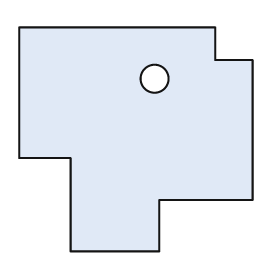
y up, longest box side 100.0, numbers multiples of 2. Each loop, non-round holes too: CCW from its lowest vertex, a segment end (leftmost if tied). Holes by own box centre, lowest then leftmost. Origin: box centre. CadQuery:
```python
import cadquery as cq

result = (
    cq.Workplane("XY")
    .moveTo(-28.0, -48.0)
    .lineTo(10.0, -48.0)
    .lineTo(10.0, -26.0)
    .lineTo(50.0, -26.0)
    .lineTo(50.0, 34.0)
    .lineTo(34.0, 34.0)
    .lineTo(34.0, 48.0)
    .lineTo(-50.0, 48.0)
    .lineTo(-50.0, -8.0)
    .lineTo(-28.0, -8.0)
    .close()
    .moveTo(8.0, 26.0)
    .circle(6.0)
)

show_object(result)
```